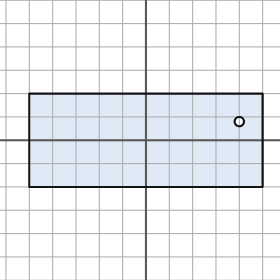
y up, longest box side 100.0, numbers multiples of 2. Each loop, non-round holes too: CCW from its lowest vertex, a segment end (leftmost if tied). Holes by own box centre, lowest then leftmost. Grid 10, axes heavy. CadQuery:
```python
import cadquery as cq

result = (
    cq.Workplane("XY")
    .moveTo(-50.0, -20.0)
    .lineTo(50.0, -20.0)
    .lineTo(50.0, 20.0)
    .lineTo(-50.0, 20.0)
    .close()
    .moveTo(40.0, 8.0)
    .circle(2.0)
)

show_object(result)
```